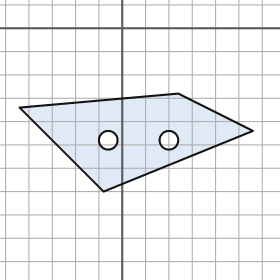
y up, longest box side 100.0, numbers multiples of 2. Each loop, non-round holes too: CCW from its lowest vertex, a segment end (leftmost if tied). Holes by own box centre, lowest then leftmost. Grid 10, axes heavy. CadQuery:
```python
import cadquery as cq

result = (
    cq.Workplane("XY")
    .moveTo(-8.0, -70.0)
    .lineTo(56.0, -44.0)
    .lineTo(24.0, -28.0)
    .lineTo(-44.0, -34.0)
    .close()
    .moveTo(-6.0, -48.0)
    .circle(4.0)
    .moveTo(20.0, -48.0)
    .circle(4.0)
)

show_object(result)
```